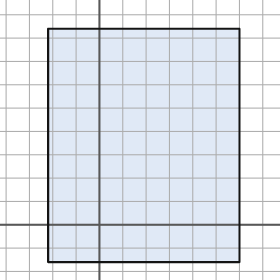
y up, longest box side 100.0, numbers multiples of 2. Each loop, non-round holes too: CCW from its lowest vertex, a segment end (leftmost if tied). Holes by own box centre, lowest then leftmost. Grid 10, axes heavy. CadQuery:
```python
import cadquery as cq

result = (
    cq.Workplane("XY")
    .moveTo(-22.0, -16.0)
    .lineTo(60.0, -16.0)
    .lineTo(60.0, 84.0)
    .lineTo(-22.0, 84.0)
    .close()
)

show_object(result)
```